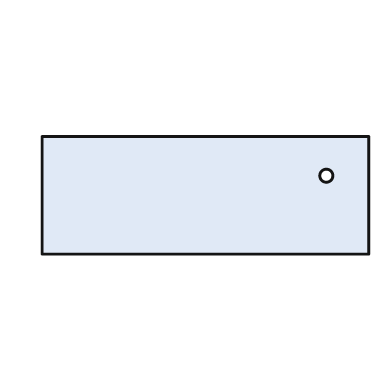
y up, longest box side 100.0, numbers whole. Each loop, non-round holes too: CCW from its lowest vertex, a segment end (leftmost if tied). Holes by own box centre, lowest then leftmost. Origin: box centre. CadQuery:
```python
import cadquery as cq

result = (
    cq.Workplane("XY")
    .moveTo(-50.0, -18.0)
    .lineTo(50.0, -18.0)
    .lineTo(50.0, 18.0)
    .lineTo(-50.0, 18.0)
    .close()
    .moveTo(37.0, 6.0)
    .circle(2.0)
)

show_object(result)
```